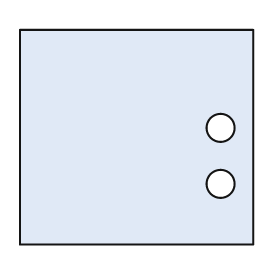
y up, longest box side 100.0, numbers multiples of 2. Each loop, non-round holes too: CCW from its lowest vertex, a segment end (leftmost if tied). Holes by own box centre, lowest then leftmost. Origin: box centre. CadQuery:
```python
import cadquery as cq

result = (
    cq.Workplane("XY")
    .moveTo(-50.0, -46.0)
    .lineTo(50.0, -46.0)
    .lineTo(50.0, 46.0)
    .lineTo(-50.0, 46.0)
    .close()
    .moveTo(36.0, -20.0)
    .circle(6.0)
    .moveTo(36.0, 4.0)
    .circle(6.0)
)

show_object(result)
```